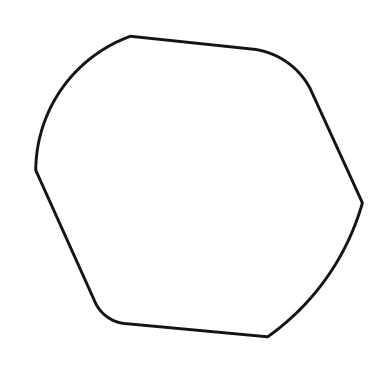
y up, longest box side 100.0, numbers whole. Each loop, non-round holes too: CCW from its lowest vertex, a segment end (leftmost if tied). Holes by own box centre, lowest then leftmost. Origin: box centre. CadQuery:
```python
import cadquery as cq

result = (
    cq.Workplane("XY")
    .moveTo(21.0, -46.0)
    .threePointArc((39.0, -28.0), (50.0, -5.0))
    .lineTo(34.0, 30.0)
    .threePointArc((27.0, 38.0), (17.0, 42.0))
    .lineTo(-21.0, 46.0)
    .threePointArc((-42.0, 30.0), (-50.0, 5.0))
    .lineTo(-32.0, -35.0)
    .threePointArc((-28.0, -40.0), (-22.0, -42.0))
    .close()
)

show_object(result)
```